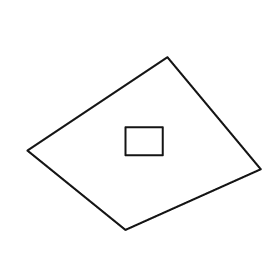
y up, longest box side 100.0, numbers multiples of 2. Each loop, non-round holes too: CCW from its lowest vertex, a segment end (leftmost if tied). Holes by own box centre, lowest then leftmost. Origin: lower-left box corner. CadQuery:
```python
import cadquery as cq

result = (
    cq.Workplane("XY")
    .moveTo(42.0, 0.0)
    .lineTo(100.0, 26.0)
    .lineTo(60.0, 74.0)
    .lineTo(0.0, 34.0)
    .close()
    .moveTo(42.0, 32.0)
    .lineTo(58.0, 32.0)
    .lineTo(58.0, 44.0)
    .lineTo(42.0, 44.0)
    .close()
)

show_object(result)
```